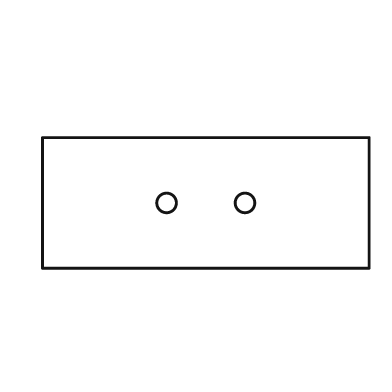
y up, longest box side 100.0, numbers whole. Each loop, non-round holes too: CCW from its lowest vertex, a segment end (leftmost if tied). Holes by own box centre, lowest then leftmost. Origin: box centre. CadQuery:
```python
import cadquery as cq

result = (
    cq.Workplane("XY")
    .moveTo(-50.0, -20.0)
    .lineTo(50.0, -20.0)
    .lineTo(50.0, 20.0)
    .lineTo(-50.0, 20.0)
    .close()
    .moveTo(-12.0, 0.0)
    .circle(3.0)
    .moveTo(12.0, 0.0)
    .circle(3.0)
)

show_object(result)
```